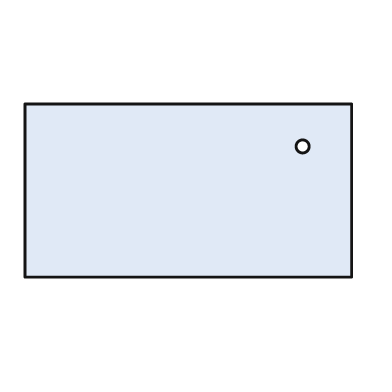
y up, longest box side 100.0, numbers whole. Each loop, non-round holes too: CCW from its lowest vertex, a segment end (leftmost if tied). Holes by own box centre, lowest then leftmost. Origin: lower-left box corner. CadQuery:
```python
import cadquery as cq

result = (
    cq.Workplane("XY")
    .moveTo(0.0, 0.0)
    .lineTo(100.0, 0.0)
    .lineTo(100.0, 53.0)
    .lineTo(0.0, 53.0)
    .close()
    .moveTo(85.0, 40.0)
    .circle(2.0)
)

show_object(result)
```